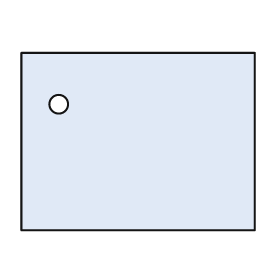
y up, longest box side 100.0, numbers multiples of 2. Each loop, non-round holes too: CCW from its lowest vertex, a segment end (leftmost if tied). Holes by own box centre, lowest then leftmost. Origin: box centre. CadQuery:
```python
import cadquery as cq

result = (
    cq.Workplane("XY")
    .moveTo(-50.0, -38.0)
    .lineTo(50.0, -38.0)
    .lineTo(50.0, 38.0)
    .lineTo(-50.0, 38.0)
    .close()
    .moveTo(-34.0, 16.0)
    .circle(4.0)
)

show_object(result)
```